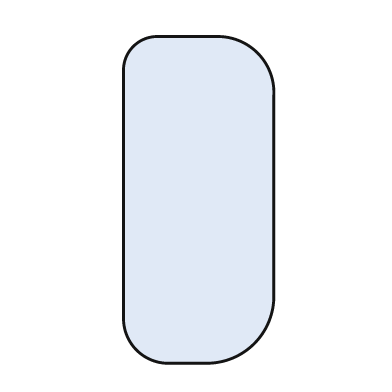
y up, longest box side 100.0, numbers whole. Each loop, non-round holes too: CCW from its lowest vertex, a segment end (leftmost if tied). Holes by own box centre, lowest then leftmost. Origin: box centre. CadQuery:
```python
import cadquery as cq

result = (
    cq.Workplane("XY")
    .moveTo(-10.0, -50.0)
    .lineTo(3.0, -50.0)
    .threePointArc((17.0, -44.0), (23.0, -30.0))
    .lineTo(23.0, 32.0)
    .threePointArc((18.0, 45.0), (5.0, 50.0))
    .lineTo(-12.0, 50.0)
    .threePointArc((-20.0, 47.0), (-23.0, 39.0))
    .lineTo(-23.0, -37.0)
    .threePointArc((-19.0, -46.0), (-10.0, -50.0))
    .close()
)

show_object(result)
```